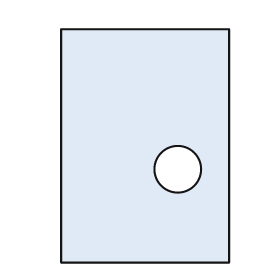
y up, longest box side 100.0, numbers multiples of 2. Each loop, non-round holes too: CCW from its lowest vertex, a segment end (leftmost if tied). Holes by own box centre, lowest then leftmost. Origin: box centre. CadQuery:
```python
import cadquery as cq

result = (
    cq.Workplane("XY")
    .moveTo(-36.0, -50.0)
    .lineTo(36.0, -50.0)
    .lineTo(36.0, 50.0)
    .lineTo(-36.0, 50.0)
    .close()
    .moveTo(14.0, -10.0)
    .circle(10.0)
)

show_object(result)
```